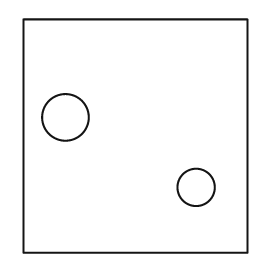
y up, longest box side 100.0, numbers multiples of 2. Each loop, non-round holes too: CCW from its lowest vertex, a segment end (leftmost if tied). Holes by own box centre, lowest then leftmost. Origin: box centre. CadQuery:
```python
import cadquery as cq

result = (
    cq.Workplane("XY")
    .moveTo(-48.0, -50.0)
    .lineTo(48.0, -50.0)
    .lineTo(48.0, 50.0)
    .lineTo(-48.0, 50.0)
    .close()
    .moveTo(26.0, -22.0)
    .circle(8.0)
    .moveTo(-30.0, 8.0)
    .circle(10.0)
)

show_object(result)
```